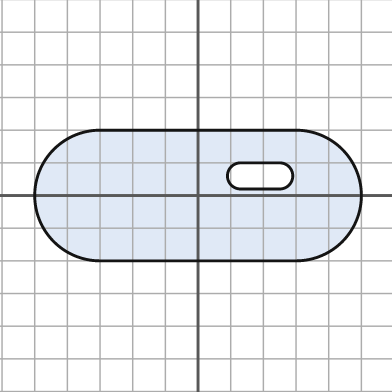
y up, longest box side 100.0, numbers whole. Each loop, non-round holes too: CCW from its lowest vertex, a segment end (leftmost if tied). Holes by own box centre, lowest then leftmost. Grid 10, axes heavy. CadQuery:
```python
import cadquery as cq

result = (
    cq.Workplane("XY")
    .moveTo(-30.0, -20.0)
    .lineTo(30.0, -20.0)
    .threePointArc((50.0, 0.0), (30.0, 20.0))
    .lineTo(-30.0, 20.0)
    .threePointArc((-50.0, 0.0), (-30.0, -20.0))
    .close()
    .moveTo(13.0, 2.0)
    .lineTo(25.0, 2.0)
    .threePointArc((29.0, 6.0), (25.0, 10.0))
    .lineTo(13.0, 10.0)
    .threePointArc((9.0, 6.0), (13.0, 2.0))
    .close()
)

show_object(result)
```